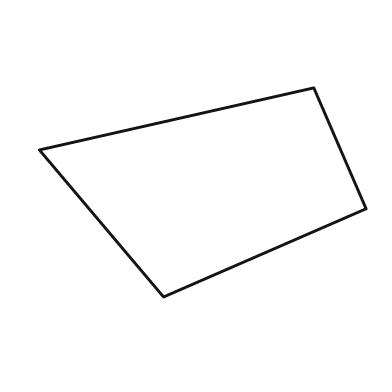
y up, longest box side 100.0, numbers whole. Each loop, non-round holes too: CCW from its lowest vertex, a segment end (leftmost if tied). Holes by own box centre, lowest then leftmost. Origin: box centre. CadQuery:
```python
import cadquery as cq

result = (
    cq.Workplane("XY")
    .moveTo(-12.0, -32.0)
    .lineTo(50.0, -5.0)
    .lineTo(34.0, 32.0)
    .lineTo(-50.0, 13.0)
    .close()
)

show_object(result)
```